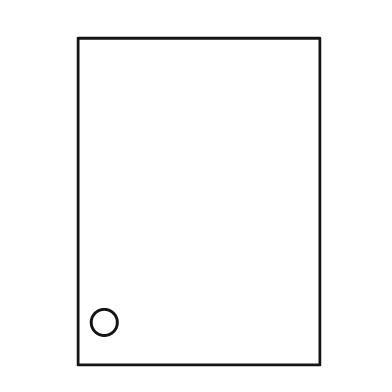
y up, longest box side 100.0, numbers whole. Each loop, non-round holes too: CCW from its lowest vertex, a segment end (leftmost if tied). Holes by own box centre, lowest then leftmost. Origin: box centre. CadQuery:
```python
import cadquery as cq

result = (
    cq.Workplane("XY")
    .moveTo(-37.0, -50.0)
    .lineTo(37.0, -50.0)
    .lineTo(37.0, 50.0)
    .lineTo(-37.0, 50.0)
    .close()
    .moveTo(-29.0, -37.0)
    .circle(4.0)
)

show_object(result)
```